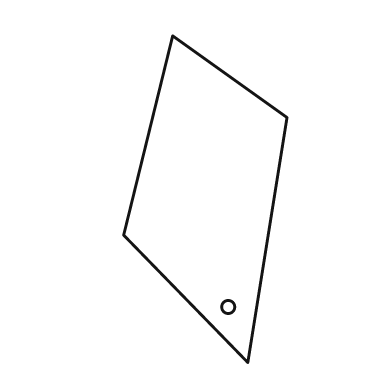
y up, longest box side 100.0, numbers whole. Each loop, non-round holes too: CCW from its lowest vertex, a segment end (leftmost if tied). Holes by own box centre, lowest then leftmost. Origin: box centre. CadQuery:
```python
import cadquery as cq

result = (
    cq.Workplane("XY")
    .moveTo(13.0, -50.0)
    .lineTo(25.0, 25.0)
    .lineTo(-10.0, 50.0)
    .lineTo(-25.0, -11.0)
    .close()
    .moveTo(7.0, -33.0)
    .circle(2.0)
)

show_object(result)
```